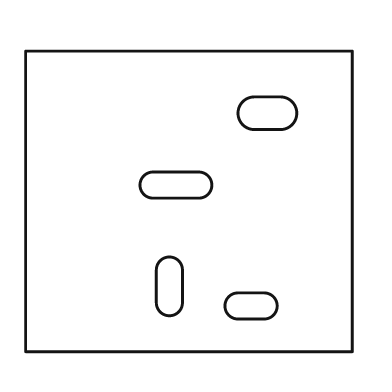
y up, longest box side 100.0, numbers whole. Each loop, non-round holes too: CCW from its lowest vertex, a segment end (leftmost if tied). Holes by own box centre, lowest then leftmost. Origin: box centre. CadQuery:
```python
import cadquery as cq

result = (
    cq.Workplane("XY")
    .moveTo(-50.0, -46.0)
    .lineTo(50.0, -46.0)
    .lineTo(50.0, 46.0)
    .lineTo(-50.0, 46.0)
    .close()
    .moveTo(15.0, -36.0)
    .lineTo(23.0, -36.0)
    .threePointArc((27.0, -32.0), (23.0, -28.0))
    .lineTo(15.0, -28.0)
    .threePointArc((11.0, -32.0), (15.0, -36.0))
    .close()
    .moveTo(-10.0, -31.0)
    .threePointArc((-6.0, -35.0), (-2.0, -31.0))
    .lineTo(-2.0, -21.0)
    .threePointArc((-6.0, -17.0), (-10.0, -21.0))
    .close()
    .moveTo(-11.0, 1.0)
    .lineTo(3.0, 1.0)
    .threePointArc((7.0, 5.0), (3.0, 9.0))
    .lineTo(-11.0, 9.0)
    .threePointArc((-15.0, 5.0), (-11.0, 1.0))
    .close()
    .moveTo(20.0, 22.0)
    .lineTo(28.0, 22.0)
    .threePointArc((33.0, 27.0), (28.0, 32.0))
    .lineTo(20.0, 32.0)
    .threePointArc((15.0, 27.0), (20.0, 22.0))
    .close()
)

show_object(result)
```